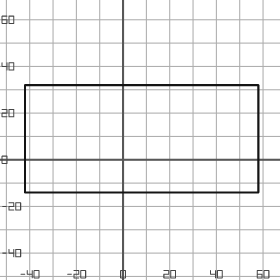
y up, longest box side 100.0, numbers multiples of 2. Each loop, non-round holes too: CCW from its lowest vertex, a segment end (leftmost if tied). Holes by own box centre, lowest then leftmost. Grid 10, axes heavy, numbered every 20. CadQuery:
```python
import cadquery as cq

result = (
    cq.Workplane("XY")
    .moveTo(-42.0, -14.0)
    .lineTo(58.0, -14.0)
    .lineTo(58.0, 32.0)
    .lineTo(-42.0, 32.0)
    .close()
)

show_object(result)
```